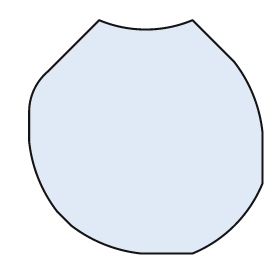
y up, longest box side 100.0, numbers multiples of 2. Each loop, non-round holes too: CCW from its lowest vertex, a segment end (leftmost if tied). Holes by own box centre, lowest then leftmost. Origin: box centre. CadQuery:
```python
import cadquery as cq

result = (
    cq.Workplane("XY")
    .moveTo(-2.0, -50.0)
    .lineTo(20.0, -50.0)
    .threePointArc((38.0, -38.0), (50.0, -20.0))
    .lineTo(50.0, 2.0)
    .threePointArc((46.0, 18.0), (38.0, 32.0))
    .lineTo(20.0, 50.0)
    .threePointArc((0.0, 46.0), (-20.0, 50.0))
    .lineTo(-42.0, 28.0)
    .threePointArc((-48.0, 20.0), (-50.0, 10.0))
    .lineTo(-50.0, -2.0)
    .threePointArc((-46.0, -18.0), (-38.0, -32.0))
    .lineTo(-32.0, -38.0)
    .threePointArc((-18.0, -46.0), (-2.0, -50.0))
    .close()
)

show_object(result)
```